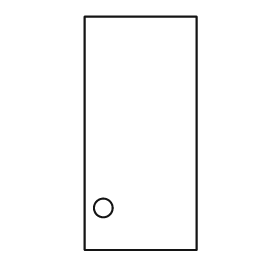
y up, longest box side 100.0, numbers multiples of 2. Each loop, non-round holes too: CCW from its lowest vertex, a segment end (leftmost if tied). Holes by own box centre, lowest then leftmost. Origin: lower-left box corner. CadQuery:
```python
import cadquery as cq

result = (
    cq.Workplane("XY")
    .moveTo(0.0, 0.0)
    .lineTo(48.0, 0.0)
    .lineTo(48.0, 100.0)
    .lineTo(0.0, 100.0)
    .close()
    .moveTo(8.0, 18.0)
    .circle(4.0)
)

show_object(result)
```